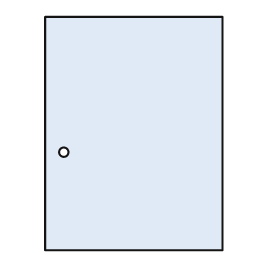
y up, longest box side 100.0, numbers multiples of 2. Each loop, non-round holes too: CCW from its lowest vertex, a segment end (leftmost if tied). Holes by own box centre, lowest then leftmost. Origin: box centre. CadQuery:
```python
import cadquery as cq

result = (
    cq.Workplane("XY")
    .moveTo(-38.0, -50.0)
    .lineTo(38.0, -50.0)
    .lineTo(38.0, 50.0)
    .lineTo(-38.0, 50.0)
    .close()
    .moveTo(-30.0, -8.0)
    .circle(2.0)
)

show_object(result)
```